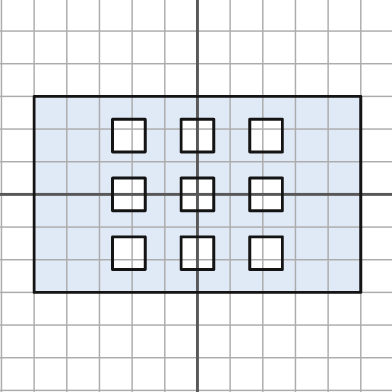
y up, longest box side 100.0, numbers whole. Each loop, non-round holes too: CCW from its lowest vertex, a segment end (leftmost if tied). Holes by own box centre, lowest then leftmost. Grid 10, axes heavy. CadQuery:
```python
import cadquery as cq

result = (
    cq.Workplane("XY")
    .moveTo(-50.0, -30.0)
    .lineTo(50.0, -30.0)
    .lineTo(50.0, 30.0)
    .lineTo(-50.0, 30.0)
    .close()
    .moveTo(-26.0, -23.0)
    .lineTo(-16.0, -23.0)
    .lineTo(-16.0, -13.0)
    .lineTo(-26.0, -13.0)
    .close()
    .moveTo(-5.0, -23.0)
    .lineTo(5.0, -23.0)
    .lineTo(5.0, -13.0)
    .lineTo(-5.0, -13.0)
    .close()
    .moveTo(16.0, -23.0)
    .lineTo(26.0, -23.0)
    .lineTo(26.0, -13.0)
    .lineTo(16.0, -13.0)
    .close()
    .moveTo(-26.0, -5.0)
    .lineTo(-16.0, -5.0)
    .lineTo(-16.0, 5.0)
    .lineTo(-26.0, 5.0)
    .close()
    .moveTo(-5.0, -5.0)
    .lineTo(5.0, -5.0)
    .lineTo(5.0, 5.0)
    .lineTo(-5.0, 5.0)
    .close()
    .moveTo(16.0, -5.0)
    .lineTo(26.0, -5.0)
    .lineTo(26.0, 5.0)
    .lineTo(16.0, 5.0)
    .close()
    .moveTo(-26.0, 13.0)
    .lineTo(-16.0, 13.0)
    .lineTo(-16.0, 23.0)
    .lineTo(-26.0, 23.0)
    .close()
    .moveTo(-5.0, 13.0)
    .lineTo(5.0, 13.0)
    .lineTo(5.0, 23.0)
    .lineTo(-5.0, 23.0)
    .close()
    .moveTo(16.0, 13.0)
    .lineTo(26.0, 13.0)
    .lineTo(26.0, 23.0)
    .lineTo(16.0, 23.0)
    .close()
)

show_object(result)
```